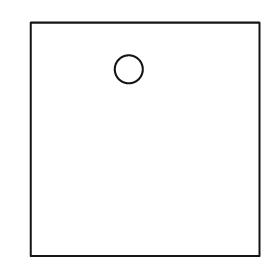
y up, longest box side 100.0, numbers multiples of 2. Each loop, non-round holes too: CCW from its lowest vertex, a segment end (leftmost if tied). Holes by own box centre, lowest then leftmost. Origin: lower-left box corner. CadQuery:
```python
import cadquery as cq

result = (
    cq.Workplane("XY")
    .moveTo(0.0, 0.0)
    .lineTo(98.0, 0.0)
    .lineTo(98.0, 100.0)
    .lineTo(0.0, 100.0)
    .close()
    .moveTo(42.0, 80.0)
    .circle(6.0)
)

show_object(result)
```